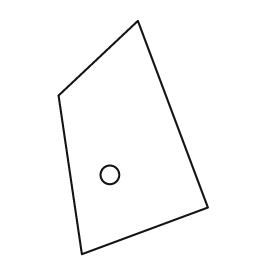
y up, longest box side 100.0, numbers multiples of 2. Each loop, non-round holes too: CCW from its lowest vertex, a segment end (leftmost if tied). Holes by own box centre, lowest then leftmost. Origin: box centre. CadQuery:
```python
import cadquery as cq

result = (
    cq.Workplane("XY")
    .moveTo(-22.0, -50.0)
    .lineTo(32.0, -30.0)
    .lineTo(2.0, 50.0)
    .lineTo(-32.0, 18.0)
    .close()
    .moveTo(-10.0, -16.0)
    .circle(4.0)
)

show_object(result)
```